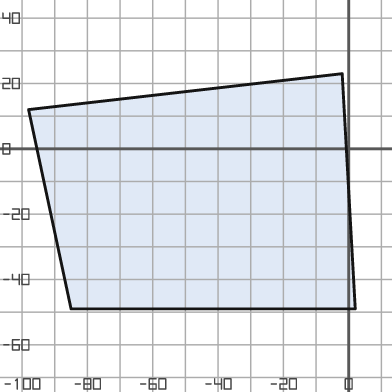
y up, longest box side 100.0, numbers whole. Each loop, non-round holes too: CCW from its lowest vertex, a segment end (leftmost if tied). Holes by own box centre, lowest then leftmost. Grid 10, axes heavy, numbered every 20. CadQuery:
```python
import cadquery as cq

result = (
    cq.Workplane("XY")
    .moveTo(-85.0, -49.0)
    .lineTo(2.0, -49.0)
    .lineTo(-2.0, 23.0)
    .lineTo(-98.0, 12.0)
    .close()
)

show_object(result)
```